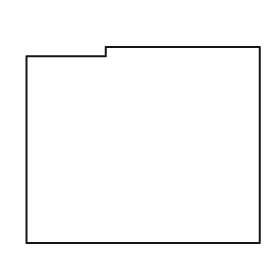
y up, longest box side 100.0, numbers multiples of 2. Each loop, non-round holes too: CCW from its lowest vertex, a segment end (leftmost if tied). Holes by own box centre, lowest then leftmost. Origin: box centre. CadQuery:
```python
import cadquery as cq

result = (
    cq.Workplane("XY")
    .moveTo(-50.0, -42.0)
    .lineTo(50.0, -42.0)
    .lineTo(50.0, 42.0)
    .lineTo(-16.0, 42.0)
    .lineTo(-16.0, 38.0)
    .lineTo(-50.0, 38.0)
    .close()
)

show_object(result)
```